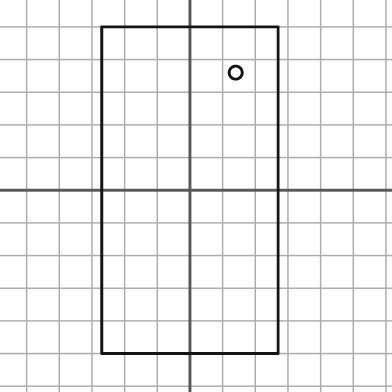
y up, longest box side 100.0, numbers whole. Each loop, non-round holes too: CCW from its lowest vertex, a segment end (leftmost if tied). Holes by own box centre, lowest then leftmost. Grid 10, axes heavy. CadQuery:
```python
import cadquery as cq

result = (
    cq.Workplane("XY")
    .moveTo(-27.0, -50.0)
    .lineTo(27.0, -50.0)
    .lineTo(27.0, 50.0)
    .lineTo(-27.0, 50.0)
    .close()
    .moveTo(14.0, 36.0)
    .circle(2.0)
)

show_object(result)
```